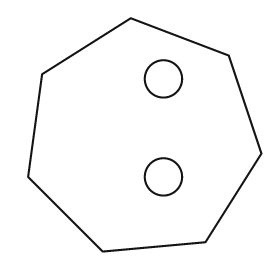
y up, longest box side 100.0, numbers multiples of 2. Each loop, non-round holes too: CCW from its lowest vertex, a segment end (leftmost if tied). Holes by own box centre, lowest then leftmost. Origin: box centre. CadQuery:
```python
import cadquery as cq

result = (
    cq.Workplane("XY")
    .moveTo(-18.0, -50.0)
    .lineTo(26.0, -46.0)
    .lineTo(50.0, -8.0)
    .lineTo(36.0, 34.0)
    .lineTo(-6.0, 50.0)
    .lineTo(-44.0, 26.0)
    .lineTo(-50.0, -18.0)
    .close()
    .moveTo(8.0, -18.0)
    .circle(8.0)
    .moveTo(8.0, 24.0)
    .circle(8.0)
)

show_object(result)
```